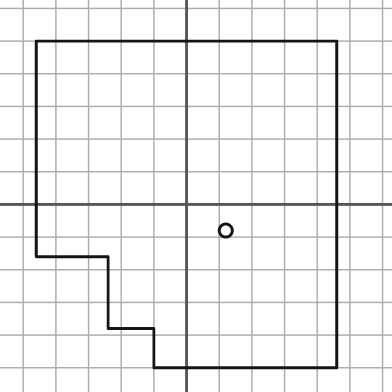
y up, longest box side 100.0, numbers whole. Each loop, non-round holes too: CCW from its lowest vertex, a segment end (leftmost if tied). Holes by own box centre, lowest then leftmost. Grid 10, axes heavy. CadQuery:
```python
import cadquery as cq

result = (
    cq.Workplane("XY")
    .moveTo(-10.0, -50.0)
    .lineTo(46.0, -50.0)
    .lineTo(46.0, 50.0)
    .lineTo(-46.0, 50.0)
    .lineTo(-46.0, -16.0)
    .lineTo(-24.0, -16.0)
    .lineTo(-24.0, -38.0)
    .lineTo(-10.0, -38.0)
    .close()
    .moveTo(12.0, -8.0)
    .circle(2.0)
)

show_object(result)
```